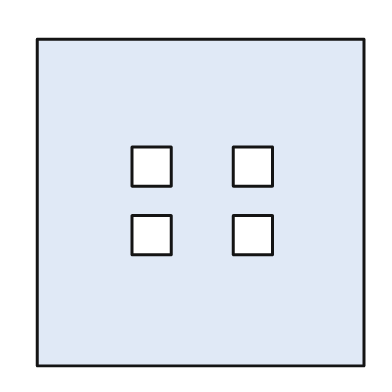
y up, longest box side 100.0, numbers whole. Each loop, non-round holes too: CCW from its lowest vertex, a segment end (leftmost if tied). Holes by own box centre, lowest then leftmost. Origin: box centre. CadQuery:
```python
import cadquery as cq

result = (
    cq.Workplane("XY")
    .moveTo(-50.0, -50.0)
    .lineTo(50.0, -50.0)
    .lineTo(50.0, 50.0)
    .lineTo(-50.0, 50.0)
    .close()
    .moveTo(-21.0, -16.0)
    .lineTo(-9.0, -16.0)
    .lineTo(-9.0, -4.0)
    .lineTo(-21.0, -4.0)
    .close()
    .moveTo(10.0, -16.0)
    .lineTo(22.0, -16.0)
    .lineTo(22.0, -4.0)
    .lineTo(10.0, -4.0)
    .close()
    .moveTo(-21.0, 5.0)
    .lineTo(-9.0, 5.0)
    .lineTo(-9.0, 17.0)
    .lineTo(-21.0, 17.0)
    .close()
    .moveTo(10.0, 5.0)
    .lineTo(22.0, 5.0)
    .lineTo(22.0, 17.0)
    .lineTo(10.0, 17.0)
    .close()
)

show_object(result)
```